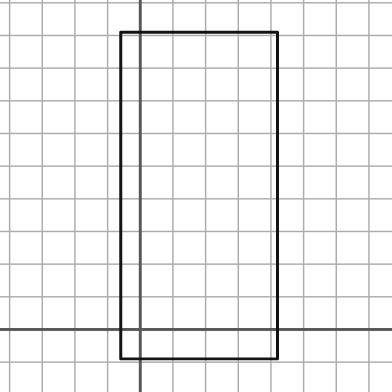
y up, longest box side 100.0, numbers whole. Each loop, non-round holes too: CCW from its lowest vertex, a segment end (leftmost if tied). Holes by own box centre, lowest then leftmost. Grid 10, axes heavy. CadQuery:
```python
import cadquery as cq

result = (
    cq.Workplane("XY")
    .moveTo(-6.0, -9.0)
    .lineTo(42.0, -9.0)
    .lineTo(42.0, 91.0)
    .lineTo(-6.0, 91.0)
    .close()
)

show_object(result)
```